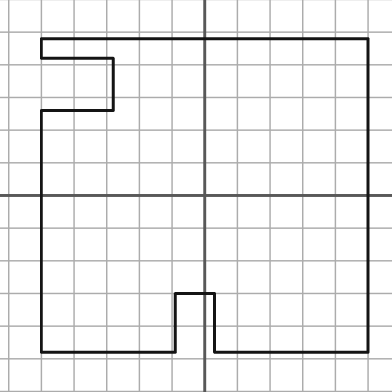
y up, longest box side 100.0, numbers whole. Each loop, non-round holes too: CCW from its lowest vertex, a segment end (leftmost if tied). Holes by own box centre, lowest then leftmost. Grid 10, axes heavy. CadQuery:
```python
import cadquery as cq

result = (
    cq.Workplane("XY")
    .moveTo(-50.0, -48.0)
    .lineTo(-9.0, -48.0)
    .lineTo(-9.0, -30.0)
    .lineTo(3.0, -30.0)
    .lineTo(3.0, -48.0)
    .lineTo(50.0, -48.0)
    .lineTo(50.0, 48.0)
    .lineTo(-50.0, 48.0)
    .lineTo(-50.0, 42.0)
    .lineTo(-28.0, 42.0)
    .lineTo(-28.0, 26.0)
    .lineTo(-50.0, 26.0)
    .close()
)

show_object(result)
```